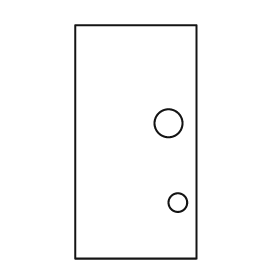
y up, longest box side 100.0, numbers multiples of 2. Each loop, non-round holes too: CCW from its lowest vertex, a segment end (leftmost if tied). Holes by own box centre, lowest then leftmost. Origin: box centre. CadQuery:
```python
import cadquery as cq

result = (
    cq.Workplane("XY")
    .moveTo(-26.0, -50.0)
    .lineTo(26.0, -50.0)
    .lineTo(26.0, 50.0)
    .lineTo(-26.0, 50.0)
    .close()
    .moveTo(18.0, -26.0)
    .circle(4.0)
    .moveTo(14.0, 8.0)
    .circle(6.0)
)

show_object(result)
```